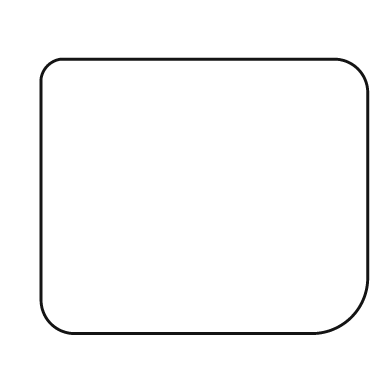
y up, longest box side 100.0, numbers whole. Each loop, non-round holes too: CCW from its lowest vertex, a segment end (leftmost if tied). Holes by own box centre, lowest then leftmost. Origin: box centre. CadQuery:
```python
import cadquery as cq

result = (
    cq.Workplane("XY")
    .moveTo(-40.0, -42.0)
    .lineTo(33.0, -42.0)
    .threePointArc((45.0, -37.0), (50.0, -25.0))
    .lineTo(50.0, 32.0)
    .threePointArc((47.0, 39.0), (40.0, 42.0))
    .lineTo(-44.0, 42.0)
    .threePointArc((-48.0, 40.0), (-50.0, 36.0))
    .lineTo(-50.0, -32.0)
    .threePointArc((-47.0, -39.0), (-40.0, -42.0))
    .close()
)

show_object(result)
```